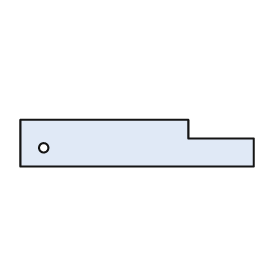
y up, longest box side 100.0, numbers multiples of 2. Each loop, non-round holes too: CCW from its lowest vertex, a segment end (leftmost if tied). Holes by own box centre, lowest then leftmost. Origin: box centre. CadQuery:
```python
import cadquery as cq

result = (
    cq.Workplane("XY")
    .moveTo(-50.0, -10.0)
    .lineTo(50.0, -10.0)
    .lineTo(50.0, 2.0)
    .lineTo(22.0, 2.0)
    .lineTo(22.0, 10.0)
    .lineTo(-50.0, 10.0)
    .close()
    .moveTo(-40.0, -2.0)
    .circle(2.0)
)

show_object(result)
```